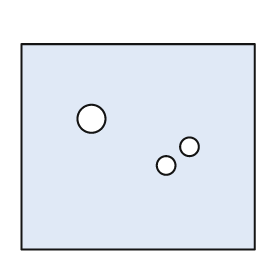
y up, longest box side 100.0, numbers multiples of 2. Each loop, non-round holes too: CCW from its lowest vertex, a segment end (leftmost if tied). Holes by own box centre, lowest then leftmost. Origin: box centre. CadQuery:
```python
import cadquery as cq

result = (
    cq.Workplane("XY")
    .moveTo(-50.0, -44.0)
    .lineTo(50.0, -44.0)
    .lineTo(50.0, 44.0)
    .lineTo(-50.0, 44.0)
    .close()
    .moveTo(12.0, -8.0)
    .circle(4.0)
    .moveTo(22.0, 0.0)
    .circle(4.0)
    .moveTo(-20.0, 12.0)
    .circle(6.0)
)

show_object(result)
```